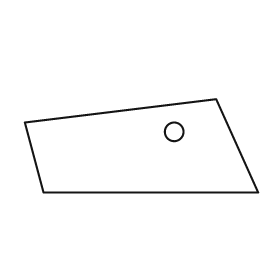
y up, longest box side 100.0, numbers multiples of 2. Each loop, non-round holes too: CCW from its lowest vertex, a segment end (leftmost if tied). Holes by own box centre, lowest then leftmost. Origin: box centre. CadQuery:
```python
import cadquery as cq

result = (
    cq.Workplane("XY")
    .moveTo(-42.0, -20.0)
    .lineTo(50.0, -20.0)
    .lineTo(32.0, 20.0)
    .lineTo(-50.0, 10.0)
    .close()
    .moveTo(14.0, 6.0)
    .circle(4.0)
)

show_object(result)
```